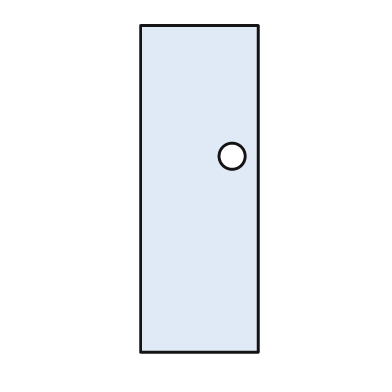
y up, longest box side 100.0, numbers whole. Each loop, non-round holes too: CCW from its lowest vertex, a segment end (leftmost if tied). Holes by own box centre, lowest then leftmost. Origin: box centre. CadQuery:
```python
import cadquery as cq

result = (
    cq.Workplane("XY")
    .moveTo(-18.0, -50.0)
    .lineTo(18.0, -50.0)
    .lineTo(18.0, 50.0)
    .lineTo(-18.0, 50.0)
    .close()
    .moveTo(10.0, 10.0)
    .circle(4.0)
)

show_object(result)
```